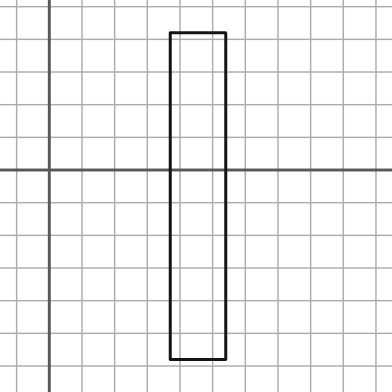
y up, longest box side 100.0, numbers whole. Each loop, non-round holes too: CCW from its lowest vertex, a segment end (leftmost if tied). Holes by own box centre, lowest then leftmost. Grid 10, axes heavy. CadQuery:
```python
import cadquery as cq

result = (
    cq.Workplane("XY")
    .moveTo(37.0, -58.0)
    .lineTo(54.0, -58.0)
    .lineTo(54.0, 42.0)
    .lineTo(37.0, 42.0)
    .close()
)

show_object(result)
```